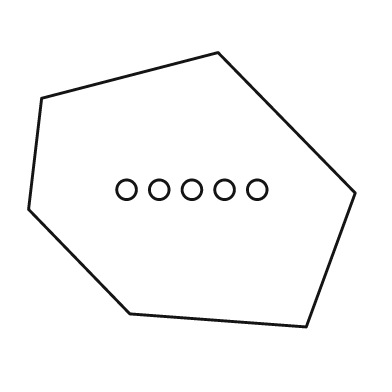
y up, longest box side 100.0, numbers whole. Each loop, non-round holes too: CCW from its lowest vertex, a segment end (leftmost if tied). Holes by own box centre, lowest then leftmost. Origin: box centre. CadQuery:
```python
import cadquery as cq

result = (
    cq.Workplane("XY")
    .moveTo(35.0, -42.0)
    .lineTo(50.0, -1.0)
    .lineTo(8.0, 42.0)
    .lineTo(-46.0, 28.0)
    .lineTo(-50.0, -6.0)
    .lineTo(-19.0, -38.0)
    .close()
    .moveTo(-20.0, 0.0)
    .circle(3.0)
    .moveTo(-10.0, 0.0)
    .circle(3.0)
    .moveTo(0.0, 0.0)
    .circle(3.0)
    .moveTo(10.0, 0.0)
    .circle(3.0)
    .moveTo(20.0, 0.0)
    .circle(3.0)
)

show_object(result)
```